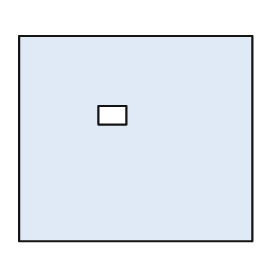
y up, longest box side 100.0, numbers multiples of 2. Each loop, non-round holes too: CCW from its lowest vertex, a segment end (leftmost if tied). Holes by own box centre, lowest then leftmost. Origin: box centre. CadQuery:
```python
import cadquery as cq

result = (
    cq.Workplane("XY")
    .moveTo(-50.0, -44.0)
    .lineTo(50.0, -44.0)
    .lineTo(50.0, 44.0)
    .lineTo(-50.0, 44.0)
    .close()
    .moveTo(-16.0, 6.0)
    .lineTo(-4.0, 6.0)
    .lineTo(-4.0, 14.0)
    .lineTo(-16.0, 14.0)
    .close()
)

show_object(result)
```